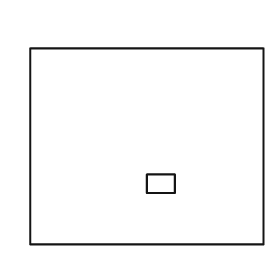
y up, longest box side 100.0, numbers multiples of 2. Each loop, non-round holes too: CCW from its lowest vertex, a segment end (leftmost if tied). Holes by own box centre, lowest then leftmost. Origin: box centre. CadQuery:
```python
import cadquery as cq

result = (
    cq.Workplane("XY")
    .moveTo(-50.0, -42.0)
    .lineTo(50.0, -42.0)
    .lineTo(50.0, 42.0)
    .lineTo(-50.0, 42.0)
    .close()
    .moveTo(0.0, -20.0)
    .lineTo(12.0, -20.0)
    .lineTo(12.0, -12.0)
    .lineTo(0.0, -12.0)
    .close()
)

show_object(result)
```